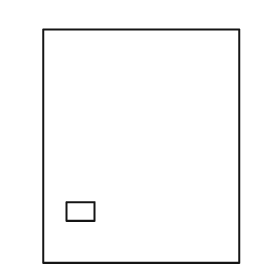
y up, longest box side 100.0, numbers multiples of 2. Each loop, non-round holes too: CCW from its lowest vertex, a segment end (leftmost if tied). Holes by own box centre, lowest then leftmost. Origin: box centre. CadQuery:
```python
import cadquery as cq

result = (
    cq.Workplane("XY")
    .moveTo(-42.0, -50.0)
    .lineTo(42.0, -50.0)
    .lineTo(42.0, 50.0)
    .lineTo(-42.0, 50.0)
    .close()
    .moveTo(-32.0, -32.0)
    .lineTo(-20.0, -32.0)
    .lineTo(-20.0, -24.0)
    .lineTo(-32.0, -24.0)
    .close()
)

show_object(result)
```